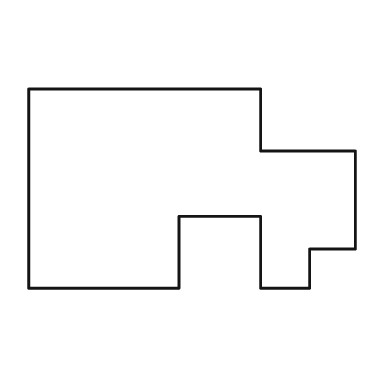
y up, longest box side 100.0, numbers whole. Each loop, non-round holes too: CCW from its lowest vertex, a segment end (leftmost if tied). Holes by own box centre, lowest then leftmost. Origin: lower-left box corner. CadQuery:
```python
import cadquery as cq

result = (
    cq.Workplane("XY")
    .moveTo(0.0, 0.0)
    .lineTo(46.0, 0.0)
    .lineTo(46.0, 22.0)
    .lineTo(71.0, 22.0)
    .lineTo(71.0, 0.0)
    .lineTo(86.0, 0.0)
    .lineTo(86.0, 12.0)
    .lineTo(100.0, 12.0)
    .lineTo(100.0, 42.0)
    .lineTo(71.0, 42.0)
    .lineTo(71.0, 61.0)
    .lineTo(0.0, 61.0)
    .close()
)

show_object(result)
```